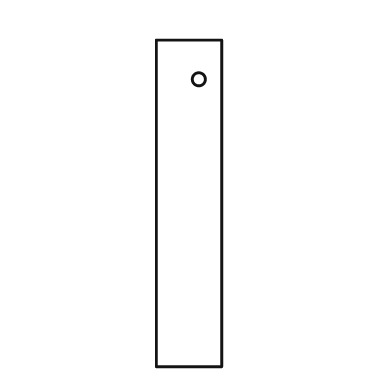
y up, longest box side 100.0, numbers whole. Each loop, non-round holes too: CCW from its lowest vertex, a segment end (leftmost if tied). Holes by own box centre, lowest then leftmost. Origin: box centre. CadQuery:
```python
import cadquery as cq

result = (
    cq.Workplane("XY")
    .moveTo(-10.0, -50.0)
    .lineTo(10.0, -50.0)
    .lineTo(10.0, 50.0)
    .lineTo(-10.0, 50.0)
    .close()
    .moveTo(3.0, 38.0)
    .circle(2.0)
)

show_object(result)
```